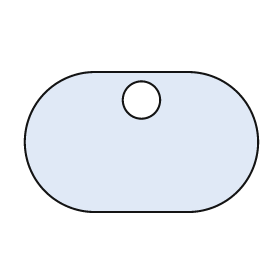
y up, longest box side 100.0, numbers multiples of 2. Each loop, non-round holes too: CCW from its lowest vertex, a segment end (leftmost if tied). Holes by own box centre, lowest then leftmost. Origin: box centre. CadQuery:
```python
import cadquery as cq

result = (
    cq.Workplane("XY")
    .moveTo(-20.0, -30.0)
    .lineTo(20.0, -30.0)
    .threePointArc((50.0, 0.0), (20.0, 30.0))
    .lineTo(-20.0, 30.0)
    .threePointArc((-50.0, 0.0), (-20.0, -30.0))
    .close()
    .moveTo(0.0, 18.0)
    .circle(8.0)
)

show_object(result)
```